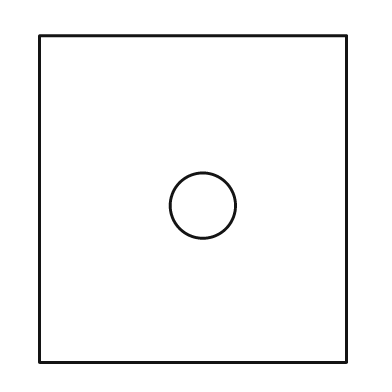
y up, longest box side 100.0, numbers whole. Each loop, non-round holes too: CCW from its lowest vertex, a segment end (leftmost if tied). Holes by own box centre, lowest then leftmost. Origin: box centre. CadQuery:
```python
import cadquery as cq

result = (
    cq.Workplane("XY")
    .moveTo(-47.0, -50.0)
    .lineTo(47.0, -50.0)
    .lineTo(47.0, 50.0)
    .lineTo(-47.0, 50.0)
    .close()
    .moveTo(3.0, -2.0)
    .circle(10.0)
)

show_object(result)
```